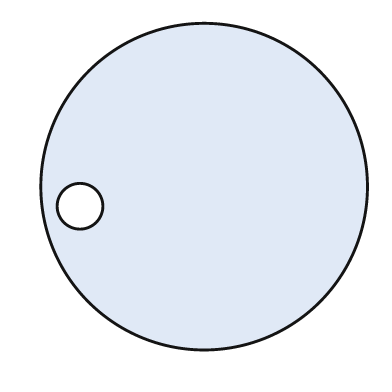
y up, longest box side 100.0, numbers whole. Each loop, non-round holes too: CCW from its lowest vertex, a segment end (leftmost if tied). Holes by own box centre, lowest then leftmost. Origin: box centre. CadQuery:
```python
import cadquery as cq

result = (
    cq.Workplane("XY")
    .moveTo(0.0, 0.0)
    .circle(50.0)
    .moveTo(-38.0, -6.0)
    .circle(7.0)
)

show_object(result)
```